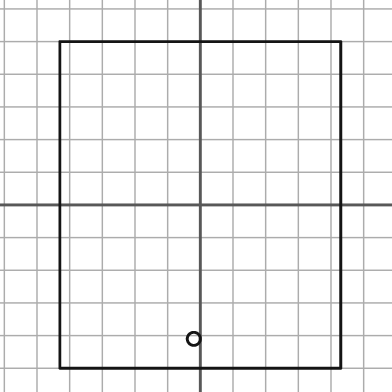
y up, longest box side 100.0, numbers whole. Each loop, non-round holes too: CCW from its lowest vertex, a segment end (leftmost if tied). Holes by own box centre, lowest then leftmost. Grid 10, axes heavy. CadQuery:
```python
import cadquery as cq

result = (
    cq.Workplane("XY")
    .moveTo(-43.0, -50.0)
    .lineTo(43.0, -50.0)
    .lineTo(43.0, 50.0)
    .lineTo(-43.0, 50.0)
    .close()
    .moveTo(-2.0, -41.0)
    .circle(2.0)
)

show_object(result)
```